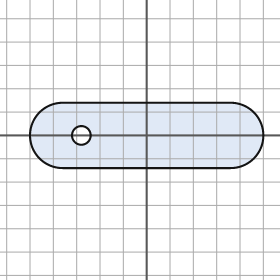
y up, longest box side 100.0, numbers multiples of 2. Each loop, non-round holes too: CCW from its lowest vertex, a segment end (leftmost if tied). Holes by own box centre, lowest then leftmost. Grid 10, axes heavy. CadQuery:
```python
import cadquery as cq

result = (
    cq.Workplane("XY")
    .moveTo(-36.0, -14.0)
    .lineTo(36.0, -14.0)
    .threePointArc((50.0, 0.0), (36.0, 14.0))
    .lineTo(-36.0, 14.0)
    .threePointArc((-50.0, 0.0), (-36.0, -14.0))
    .close()
    .moveTo(-28.0, 0.0)
    .circle(4.0)
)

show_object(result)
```